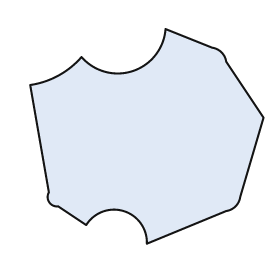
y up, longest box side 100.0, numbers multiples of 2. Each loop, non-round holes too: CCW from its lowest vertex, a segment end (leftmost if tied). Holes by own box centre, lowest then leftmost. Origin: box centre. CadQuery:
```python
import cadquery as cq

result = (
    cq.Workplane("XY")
    .moveTo(0.0, -46.0)
    .lineTo(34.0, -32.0)
    .threePointArc((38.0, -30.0), (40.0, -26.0))
    .lineTo(50.0, 8.0)
    .lineTo(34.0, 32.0)
    .threePointArc((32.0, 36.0), (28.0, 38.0))
    .lineTo(8.0, 46.0)
    .threePointArc((-6.0, 28.0), (-28.0, 34.0))
    .threePointArc((-38.0, 26.0), (-50.0, 22.0))
    .lineTo(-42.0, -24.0)
    .threePointArc((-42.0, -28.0), (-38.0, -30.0))
    .lineTo(-26.0, -38.0)
    .threePointArc((-10.0, -32.0), (0.0, -46.0))
    .close()
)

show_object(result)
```